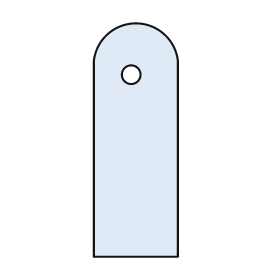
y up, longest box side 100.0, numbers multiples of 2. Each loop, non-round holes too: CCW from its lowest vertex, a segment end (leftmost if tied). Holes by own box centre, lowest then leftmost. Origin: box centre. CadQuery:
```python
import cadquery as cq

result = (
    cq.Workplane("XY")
    .moveTo(-18.0, -50.0)
    .lineTo(18.0, -50.0)
    .lineTo(18.0, 34.0)
    .threePointArc((0.0, 50.0), (-18.0, 34.0))
    .close()
    .moveTo(-2.0, 28.0)
    .circle(4.0)
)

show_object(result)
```